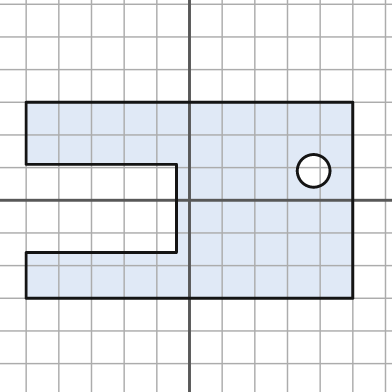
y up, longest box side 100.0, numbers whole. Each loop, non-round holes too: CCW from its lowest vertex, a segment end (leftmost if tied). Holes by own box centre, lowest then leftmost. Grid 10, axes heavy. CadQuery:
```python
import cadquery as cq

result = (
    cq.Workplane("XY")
    .moveTo(-50.0, -30.0)
    .lineTo(50.0, -30.0)
    .lineTo(50.0, 30.0)
    .lineTo(-50.0, 30.0)
    .lineTo(-50.0, 11.0)
    .lineTo(-4.0, 11.0)
    .lineTo(-4.0, -16.0)
    .lineTo(-50.0, -16.0)
    .close()
    .moveTo(38.0, 9.0)
    .circle(5.0)
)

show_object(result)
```